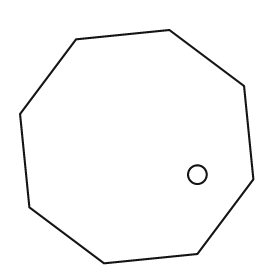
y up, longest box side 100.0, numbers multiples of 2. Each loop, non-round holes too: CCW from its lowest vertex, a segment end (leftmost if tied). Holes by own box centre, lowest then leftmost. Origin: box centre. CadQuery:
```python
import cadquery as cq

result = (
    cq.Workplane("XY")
    .moveTo(-14.0, -50.0)
    .lineTo(26.0, -46.0)
    .lineTo(50.0, -14.0)
    .lineTo(46.0, 26.0)
    .lineTo(14.0, 50.0)
    .lineTo(-26.0, 46.0)
    .lineTo(-50.0, 14.0)
    .lineTo(-46.0, -26.0)
    .close()
    .moveTo(26.0, -12.0)
    .circle(4.0)
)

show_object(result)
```